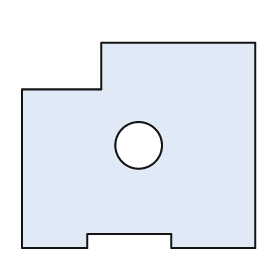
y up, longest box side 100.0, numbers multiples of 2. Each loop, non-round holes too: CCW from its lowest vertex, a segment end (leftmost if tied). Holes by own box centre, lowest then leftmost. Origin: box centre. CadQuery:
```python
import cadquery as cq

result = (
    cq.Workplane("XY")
    .moveTo(-50.0, -44.0)
    .lineTo(-22.0, -44.0)
    .lineTo(-22.0, -38.0)
    .lineTo(14.0, -38.0)
    .lineTo(14.0, -44.0)
    .lineTo(50.0, -44.0)
    .lineTo(50.0, 44.0)
    .lineTo(-16.0, 44.0)
    .lineTo(-16.0, 24.0)
    .lineTo(-50.0, 24.0)
    .close()
    .moveTo(0.0, 0.0)
    .circle(10.0)
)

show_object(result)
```